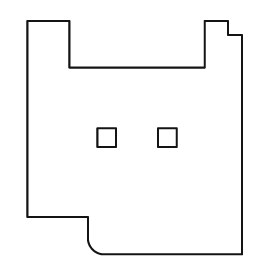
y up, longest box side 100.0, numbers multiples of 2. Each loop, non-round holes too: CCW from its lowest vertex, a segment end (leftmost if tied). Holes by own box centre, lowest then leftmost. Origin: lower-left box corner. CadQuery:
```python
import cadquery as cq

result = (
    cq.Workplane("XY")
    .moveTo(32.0, 0.0)
    .lineTo(92.0, 0.0)
    .lineTo(92.0, 94.0)
    .lineTo(86.0, 94.0)
    .lineTo(86.0, 100.0)
    .lineTo(76.0, 100.0)
    .lineTo(76.0, 80.0)
    .lineTo(18.0, 80.0)
    .lineTo(18.0, 100.0)
    .lineTo(0.0, 100.0)
    .lineTo(0.0, 16.0)
    .lineTo(26.0, 16.0)
    .lineTo(26.0, 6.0)
    .threePointArc((28.0, 2.0), (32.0, 0.0))
    .close()
    .moveTo(30.0, 46.0)
    .lineTo(38.0, 46.0)
    .lineTo(38.0, 54.0)
    .lineTo(30.0, 54.0)
    .close()
    .moveTo(56.0, 46.0)
    .lineTo(64.0, 46.0)
    .lineTo(64.0, 54.0)
    .lineTo(56.0, 54.0)
    .close()
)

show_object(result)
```